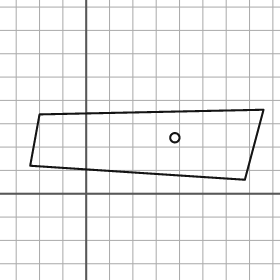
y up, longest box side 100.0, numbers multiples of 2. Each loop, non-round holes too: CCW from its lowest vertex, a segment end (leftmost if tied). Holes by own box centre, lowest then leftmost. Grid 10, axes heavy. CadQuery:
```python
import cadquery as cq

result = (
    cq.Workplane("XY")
    .moveTo(68.0, 6.0)
    .lineTo(76.0, 36.0)
    .lineTo(-20.0, 34.0)
    .lineTo(-24.0, 12.0)
    .close()
    .moveTo(38.0, 24.0)
    .circle(2.0)
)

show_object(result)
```